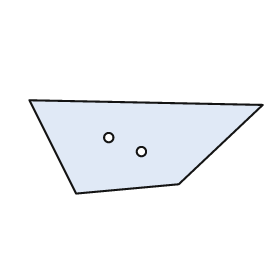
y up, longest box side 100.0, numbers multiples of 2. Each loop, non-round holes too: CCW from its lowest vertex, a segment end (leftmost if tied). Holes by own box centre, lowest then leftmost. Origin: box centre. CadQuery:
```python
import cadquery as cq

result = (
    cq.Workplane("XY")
    .moveTo(-30.0, -20.0)
    .lineTo(14.0, -16.0)
    .lineTo(50.0, 18.0)
    .lineTo(-50.0, 20.0)
    .close()
    .moveTo(-2.0, -2.0)
    .circle(2.0)
    .moveTo(-16.0, 4.0)
    .circle(2.0)
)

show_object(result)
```